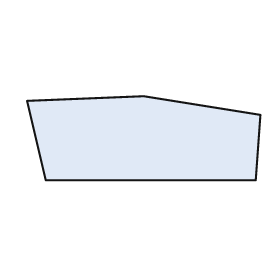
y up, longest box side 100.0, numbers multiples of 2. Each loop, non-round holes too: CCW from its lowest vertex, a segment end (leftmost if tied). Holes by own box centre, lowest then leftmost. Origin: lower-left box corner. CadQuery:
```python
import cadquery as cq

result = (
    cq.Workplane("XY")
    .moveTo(8.0, 0.0)
    .lineTo(98.0, 0.0)
    .lineTo(100.0, 28.0)
    .lineTo(50.0, 36.0)
    .lineTo(0.0, 34.0)
    .close()
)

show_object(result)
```